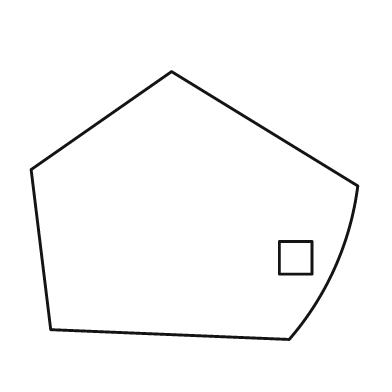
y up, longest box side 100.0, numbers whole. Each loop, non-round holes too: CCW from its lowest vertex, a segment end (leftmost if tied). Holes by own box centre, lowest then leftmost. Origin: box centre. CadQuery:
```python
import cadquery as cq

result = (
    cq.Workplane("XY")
    .moveTo(29.0, -41.0)
    .threePointArc((43.0, -19.0), (50.0, 6.0))
    .lineTo(-7.0, 41.0)
    .lineTo(-50.0, 11.0)
    .lineTo(-44.0, -38.0)
    .close()
    .moveTo(26.0, -21.0)
    .lineTo(36.0, -21.0)
    .lineTo(36.0, -11.0)
    .lineTo(26.0, -11.0)
    .close()
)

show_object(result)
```